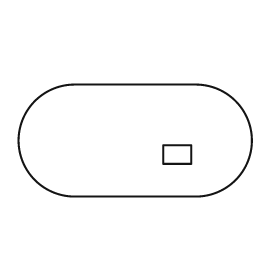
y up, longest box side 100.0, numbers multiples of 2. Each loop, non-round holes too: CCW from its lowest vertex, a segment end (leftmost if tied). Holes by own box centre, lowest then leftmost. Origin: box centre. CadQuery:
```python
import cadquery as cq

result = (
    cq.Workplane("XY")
    .moveTo(-26.0, -24.0)
    .lineTo(26.0, -24.0)
    .threePointArc((50.0, 0.0), (26.0, 24.0))
    .lineTo(-26.0, 24.0)
    .threePointArc((-50.0, 0.0), (-26.0, -24.0))
    .close()
    .moveTo(12.0, -10.0)
    .lineTo(24.0, -10.0)
    .lineTo(24.0, -2.0)
    .lineTo(12.0, -2.0)
    .close()
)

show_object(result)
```